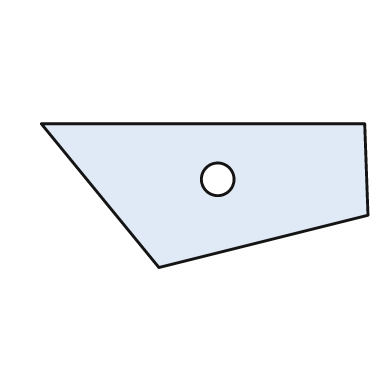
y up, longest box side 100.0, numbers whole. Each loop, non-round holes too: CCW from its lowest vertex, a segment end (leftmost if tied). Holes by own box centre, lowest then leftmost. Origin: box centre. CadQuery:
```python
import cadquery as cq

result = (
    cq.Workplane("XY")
    .moveTo(-14.0, -22.0)
    .lineTo(50.0, -6.0)
    .lineTo(49.0, 22.0)
    .lineTo(-50.0, 22.0)
    .close()
    .moveTo(4.0, 5.0)
    .circle(5.0)
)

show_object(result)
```